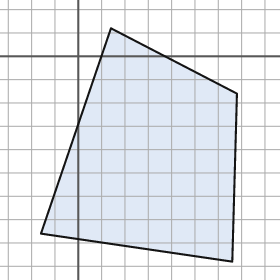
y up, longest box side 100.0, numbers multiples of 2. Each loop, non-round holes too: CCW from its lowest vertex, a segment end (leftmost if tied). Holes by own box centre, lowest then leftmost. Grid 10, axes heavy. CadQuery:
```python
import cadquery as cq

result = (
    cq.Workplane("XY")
    .moveTo(66.0, -88.0)
    .lineTo(68.0, -16.0)
    .lineTo(14.0, 12.0)
    .lineTo(-16.0, -76.0)
    .close()
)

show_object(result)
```